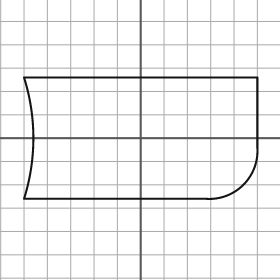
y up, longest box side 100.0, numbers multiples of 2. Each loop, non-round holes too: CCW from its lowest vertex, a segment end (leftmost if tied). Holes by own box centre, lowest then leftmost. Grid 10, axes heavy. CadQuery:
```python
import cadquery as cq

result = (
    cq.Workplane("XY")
    .moveTo(-50.0, -26.0)
    .lineTo(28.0, -26.0)
    .threePointArc((44.0, -20.0), (50.0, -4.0))
    .lineTo(50.0, 26.0)
    .lineTo(-50.0, 26.0)
    .threePointArc((-46.0, 0.0), (-50.0, -26.0))
    .close()
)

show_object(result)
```